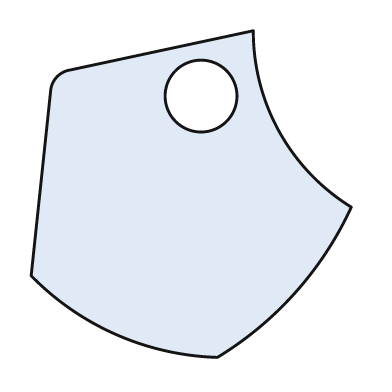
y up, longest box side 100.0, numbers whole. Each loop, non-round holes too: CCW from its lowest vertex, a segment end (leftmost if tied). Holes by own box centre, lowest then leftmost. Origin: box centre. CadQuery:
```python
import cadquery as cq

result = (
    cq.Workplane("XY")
    .moveTo(8.0, -50.0)
    .threePointArc((32.0, -30.0), (49.0, -4.0))
    .threePointArc((27.0, 19.0), (19.0, 50.0))
    .lineTo(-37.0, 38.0)
    .threePointArc((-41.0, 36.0), (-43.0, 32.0))
    .lineTo(-49.0, -25.0)
    .threePointArc((-23.0, -43.0), (8.0, -50.0))
    .close()
    .moveTo(3.0, 30.0)
    .circle(11.0)
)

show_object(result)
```